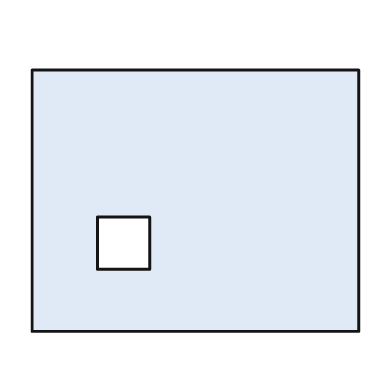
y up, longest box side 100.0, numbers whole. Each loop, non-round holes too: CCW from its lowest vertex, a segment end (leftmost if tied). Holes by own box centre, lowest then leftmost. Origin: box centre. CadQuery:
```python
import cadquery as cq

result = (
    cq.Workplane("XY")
    .moveTo(-50.0, -40.0)
    .lineTo(50.0, -40.0)
    .lineTo(50.0, 40.0)
    .lineTo(-50.0, 40.0)
    .close()
    .moveTo(-30.0, -21.0)
    .lineTo(-14.0, -21.0)
    .lineTo(-14.0, -5.0)
    .lineTo(-30.0, -5.0)
    .close()
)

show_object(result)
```